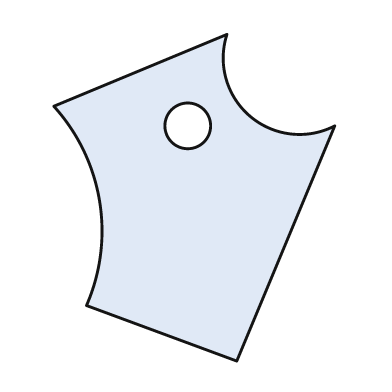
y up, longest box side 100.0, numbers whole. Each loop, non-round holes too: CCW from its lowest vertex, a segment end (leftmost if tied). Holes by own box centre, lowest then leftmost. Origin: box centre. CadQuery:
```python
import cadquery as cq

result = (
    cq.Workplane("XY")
    .moveTo(13.0, -50.0)
    .lineTo(43.0, 22.0)
    .threePointArc((17.0, 25.0), (10.0, 50.0))
    .lineTo(-43.0, 28.0)
    .threePointArc((-29.0, -1.0), (-33.0, -33.0))
    .close()
    .moveTo(-2.0, 22.0)
    .circle(7.0)
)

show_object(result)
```